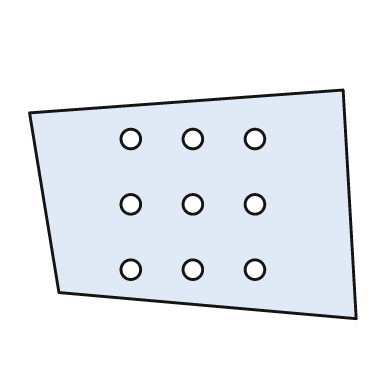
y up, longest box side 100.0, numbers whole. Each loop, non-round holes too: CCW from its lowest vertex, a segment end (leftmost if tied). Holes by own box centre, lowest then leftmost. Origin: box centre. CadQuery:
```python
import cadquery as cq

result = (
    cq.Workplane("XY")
    .moveTo(50.0, -35.0)
    .lineTo(46.0, 35.0)
    .lineTo(-50.0, 28.0)
    .lineTo(-41.0, -27.0)
    .close()
    .moveTo(-19.0, -20.0)
    .circle(3.0)
    .moveTo(0.0, -20.0)
    .circle(3.0)
    .moveTo(19.0, -20.0)
    .circle(3.0)
    .moveTo(-19.0, 0.0)
    .circle(3.0)
    .moveTo(0.0, 0.0)
    .circle(3.0)
    .moveTo(19.0, 0.0)
    .circle(3.0)
    .moveTo(-19.0, 20.0)
    .circle(3.0)
    .moveTo(0.0, 20.0)
    .circle(3.0)
    .moveTo(19.0, 20.0)
    .circle(3.0)
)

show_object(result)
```